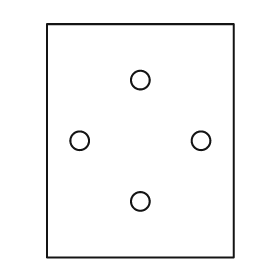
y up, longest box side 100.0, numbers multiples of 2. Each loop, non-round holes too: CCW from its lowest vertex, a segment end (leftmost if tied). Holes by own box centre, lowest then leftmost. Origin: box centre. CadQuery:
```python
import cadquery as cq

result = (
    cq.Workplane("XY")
    .moveTo(-40.0, -50.0)
    .lineTo(40.0, -50.0)
    .lineTo(40.0, 50.0)
    .lineTo(-40.0, 50.0)
    .close()
    .moveTo(0.0, -26.0)
    .circle(4.0)
    .moveTo(-26.0, 0.0)
    .circle(4.0)
    .moveTo(26.0, 0.0)
    .circle(4.0)
    .moveTo(0.0, 26.0)
    .circle(4.0)
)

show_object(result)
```